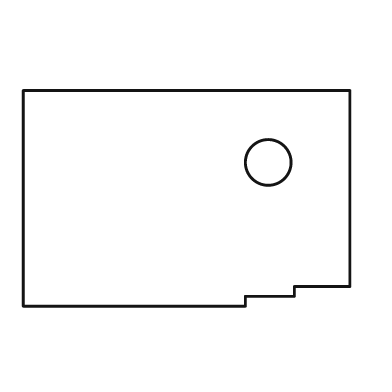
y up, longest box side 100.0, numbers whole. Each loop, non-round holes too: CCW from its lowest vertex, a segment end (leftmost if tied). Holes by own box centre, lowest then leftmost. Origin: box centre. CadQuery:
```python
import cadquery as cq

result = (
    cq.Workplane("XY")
    .moveTo(-50.0, -33.0)
    .lineTo(18.0, -33.0)
    .lineTo(18.0, -30.0)
    .lineTo(33.0, -30.0)
    .lineTo(33.0, -27.0)
    .lineTo(50.0, -27.0)
    .lineTo(50.0, 33.0)
    .lineTo(-50.0, 33.0)
    .close()
    .moveTo(25.0, 11.0)
    .circle(7.0)
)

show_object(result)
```